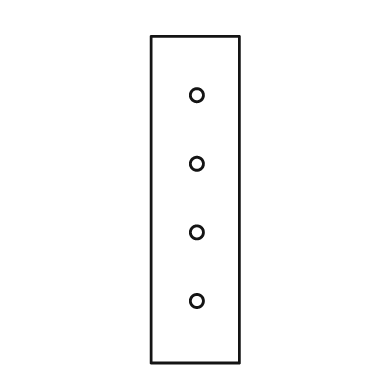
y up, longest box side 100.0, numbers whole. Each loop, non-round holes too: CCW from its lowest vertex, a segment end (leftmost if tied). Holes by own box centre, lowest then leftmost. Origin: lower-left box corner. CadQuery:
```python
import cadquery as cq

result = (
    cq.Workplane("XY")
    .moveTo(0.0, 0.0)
    .lineTo(27.0, 0.0)
    .lineTo(27.0, 100.0)
    .lineTo(0.0, 100.0)
    .close()
    .moveTo(14.0, 19.0)
    .circle(2.0)
    .moveTo(14.0, 40.0)
    .circle(2.0)
    .moveTo(14.0, 61.0)
    .circle(2.0)
    .moveTo(14.0, 82.0)
    .circle(2.0)
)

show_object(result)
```